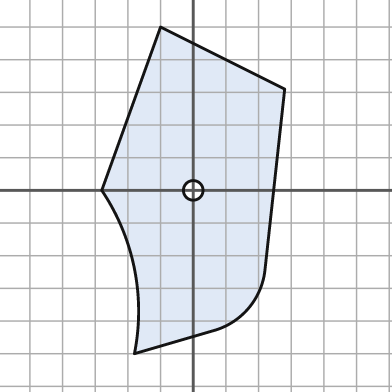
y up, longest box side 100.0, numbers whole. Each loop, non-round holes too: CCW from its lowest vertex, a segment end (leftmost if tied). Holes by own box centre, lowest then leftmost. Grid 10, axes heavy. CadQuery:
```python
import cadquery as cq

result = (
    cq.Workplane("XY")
    .moveTo(-18.0, -50.0)
    .lineTo(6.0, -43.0)
    .threePointArc((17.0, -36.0), (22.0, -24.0))
    .lineTo(28.0, 31.0)
    .lineTo(-10.0, 50.0)
    .lineTo(-28.0, 0.0)
    .threePointArc((-18.0, -24.0), (-18.0, -50.0))
    .close()
    .moveTo(0.0, 0.0)
    .circle(3.0)
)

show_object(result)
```